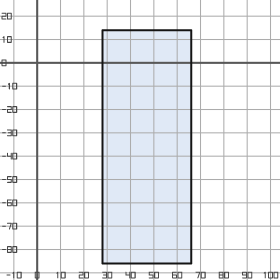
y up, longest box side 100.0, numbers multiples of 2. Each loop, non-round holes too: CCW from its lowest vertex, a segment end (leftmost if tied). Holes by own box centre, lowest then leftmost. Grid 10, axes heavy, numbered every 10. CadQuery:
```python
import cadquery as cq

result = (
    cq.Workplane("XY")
    .moveTo(28.0, -86.0)
    .lineTo(66.0, -86.0)
    .lineTo(66.0, 14.0)
    .lineTo(28.0, 14.0)
    .close()
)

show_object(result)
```